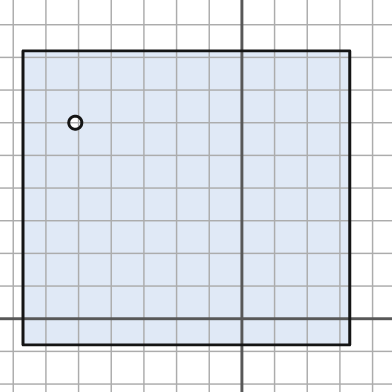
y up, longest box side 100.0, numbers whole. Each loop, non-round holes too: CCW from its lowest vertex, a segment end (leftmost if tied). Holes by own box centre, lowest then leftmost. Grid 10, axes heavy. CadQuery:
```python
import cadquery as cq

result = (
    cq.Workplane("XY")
    .moveTo(-67.0, -8.0)
    .lineTo(33.0, -8.0)
    .lineTo(33.0, 82.0)
    .lineTo(-67.0, 82.0)
    .close()
    .moveTo(-51.0, 60.0)
    .circle(2.0)
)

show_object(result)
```